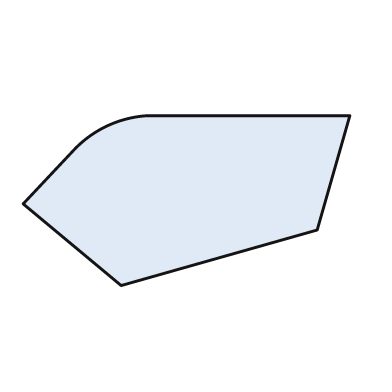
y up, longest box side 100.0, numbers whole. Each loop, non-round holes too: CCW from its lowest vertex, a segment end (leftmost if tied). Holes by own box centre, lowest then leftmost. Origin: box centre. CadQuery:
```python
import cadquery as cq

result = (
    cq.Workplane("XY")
    .moveTo(-20.0, -26.0)
    .lineTo(40.0, -9.0)
    .lineTo(50.0, 26.0)
    .lineTo(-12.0, 26.0)
    .threePointArc((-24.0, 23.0), (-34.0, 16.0))
    .lineTo(-50.0, -1.0)
    .close()
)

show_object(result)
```